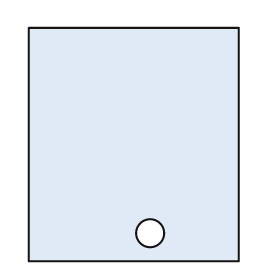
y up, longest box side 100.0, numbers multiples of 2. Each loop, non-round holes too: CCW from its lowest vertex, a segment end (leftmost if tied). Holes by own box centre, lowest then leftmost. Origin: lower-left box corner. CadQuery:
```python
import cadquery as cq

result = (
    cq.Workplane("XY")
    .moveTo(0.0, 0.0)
    .lineTo(90.0, 0.0)
    .lineTo(90.0, 100.0)
    .lineTo(0.0, 100.0)
    .close()
    .moveTo(52.0, 12.0)
    .circle(6.0)
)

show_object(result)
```